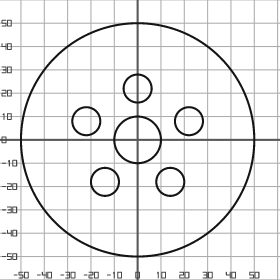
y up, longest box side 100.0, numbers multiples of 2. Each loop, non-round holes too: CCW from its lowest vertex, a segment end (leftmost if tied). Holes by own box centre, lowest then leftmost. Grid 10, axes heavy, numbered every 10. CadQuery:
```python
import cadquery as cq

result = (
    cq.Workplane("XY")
    .moveTo(0.0, 0.0)
    .circle(50.0)
    .moveTo(-14.0, -18.0)
    .circle(6.0)
    .moveTo(14.0, -18.0)
    .circle(6.0)
    .moveTo(0.0, 0.0)
    .circle(10.0)
    .moveTo(-22.0, 8.0)
    .circle(6.0)
    .moveTo(22.0, 8.0)
    .circle(6.0)
    .moveTo(0.0, 22.0)
    .circle(6.0)
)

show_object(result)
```